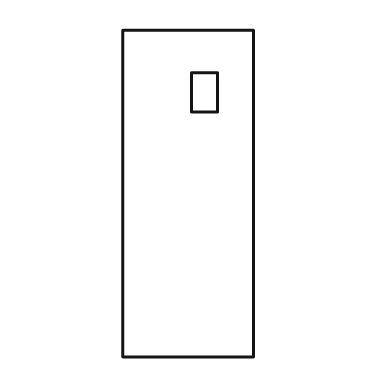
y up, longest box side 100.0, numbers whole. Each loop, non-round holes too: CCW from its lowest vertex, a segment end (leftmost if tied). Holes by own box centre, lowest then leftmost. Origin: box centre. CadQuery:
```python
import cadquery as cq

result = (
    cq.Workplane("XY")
    .moveTo(-20.0, -50.0)
    .lineTo(20.0, -50.0)
    .lineTo(20.0, 50.0)
    .lineTo(-20.0, 50.0)
    .close()
    .moveTo(1.0, 25.0)
    .lineTo(9.0, 25.0)
    .lineTo(9.0, 37.0)
    .lineTo(1.0, 37.0)
    .close()
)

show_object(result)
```